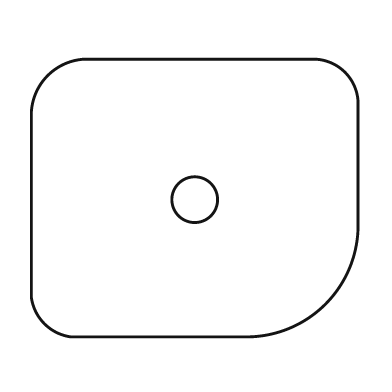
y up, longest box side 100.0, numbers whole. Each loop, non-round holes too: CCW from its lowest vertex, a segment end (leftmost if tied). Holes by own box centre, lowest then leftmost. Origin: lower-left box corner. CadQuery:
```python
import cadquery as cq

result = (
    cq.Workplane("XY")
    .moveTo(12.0, 0.0)
    .lineTo(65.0, 0.0)
    .threePointArc((90.0, 10.0), (100.0, 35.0))
    .lineTo(100.0, 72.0)
    .threePointArc((96.0, 81.0), (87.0, 85.0))
    .lineTo(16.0, 85.0)
    .threePointArc((5.0, 80.0), (0.0, 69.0))
    .lineTo(0.0, 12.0)
    .threePointArc((4.0, 4.0), (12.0, 0.0))
    .close()
    .moveTo(50.0, 42.0)
    .circle(7.0)
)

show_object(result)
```